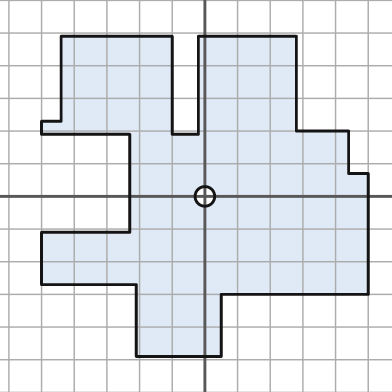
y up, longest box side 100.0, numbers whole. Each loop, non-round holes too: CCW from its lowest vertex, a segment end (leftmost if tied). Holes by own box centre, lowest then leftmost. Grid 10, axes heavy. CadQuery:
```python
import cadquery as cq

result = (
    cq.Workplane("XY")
    .moveTo(-21.0, -49.0)
    .lineTo(5.0, -49.0)
    .lineTo(5.0, -30.0)
    .lineTo(50.0, -30.0)
    .lineTo(50.0, 7.0)
    .lineTo(44.0, 7.0)
    .lineTo(44.0, 20.0)
    .lineTo(28.0, 20.0)
    .lineTo(28.0, 49.0)
    .lineTo(-2.0, 49.0)
    .lineTo(-2.0, 19.0)
    .lineTo(-10.0, 19.0)
    .lineTo(-10.0, 49.0)
    .lineTo(-44.0, 49.0)
    .lineTo(-44.0, 23.0)
    .lineTo(-50.0, 23.0)
    .lineTo(-50.0, 19.0)
    .lineTo(-23.0, 19.0)
    .lineTo(-23.0, -11.0)
    .lineTo(-50.0, -11.0)
    .lineTo(-50.0, -27.0)
    .lineTo(-21.0, -27.0)
    .close()
    .moveTo(0.0, 0.0)
    .circle(3.0)
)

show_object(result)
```